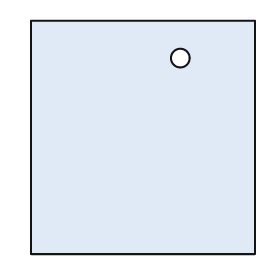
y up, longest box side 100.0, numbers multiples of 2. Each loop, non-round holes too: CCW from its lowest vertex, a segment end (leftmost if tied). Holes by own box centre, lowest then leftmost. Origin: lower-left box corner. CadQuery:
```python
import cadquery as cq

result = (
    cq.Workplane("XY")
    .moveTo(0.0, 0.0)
    .lineTo(96.0, 0.0)
    .lineTo(96.0, 100.0)
    .lineTo(0.0, 100.0)
    .close()
    .moveTo(64.0, 84.0)
    .circle(4.0)
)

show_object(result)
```